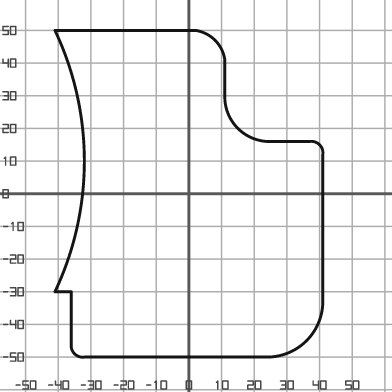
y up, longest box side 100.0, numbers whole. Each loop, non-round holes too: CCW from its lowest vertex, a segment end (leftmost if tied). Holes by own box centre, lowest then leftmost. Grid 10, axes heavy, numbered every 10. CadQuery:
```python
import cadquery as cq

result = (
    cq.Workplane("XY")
    .moveTo(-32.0, -50.0)
    .lineTo(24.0, -50.0)
    .threePointArc((36.0, -45.0), (41.0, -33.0))
    .lineTo(41.0, 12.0)
    .threePointArc((40.0, 15.0), (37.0, 16.0))
    .lineTo(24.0, 16.0)
    .threePointArc((15.0, 20.0), (11.0, 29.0))
    .lineTo(11.0, 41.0)
    .threePointArc((8.0, 47.0), (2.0, 50.0))
    .lineTo(-41.0, 50.0)
    .threePointArc((-32.0, 10.0), (-41.0, -30.0))
    .lineTo(-36.0, -30.0)
    .lineTo(-36.0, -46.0)
    .threePointArc((-35.0, -49.0), (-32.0, -50.0))
    .close()
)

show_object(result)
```